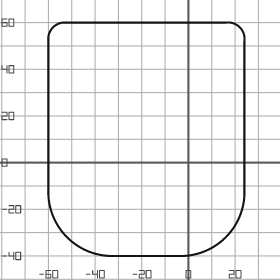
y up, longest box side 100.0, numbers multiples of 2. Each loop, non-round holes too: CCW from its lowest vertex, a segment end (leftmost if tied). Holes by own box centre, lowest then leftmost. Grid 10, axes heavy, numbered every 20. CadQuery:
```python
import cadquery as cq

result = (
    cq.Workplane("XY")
    .moveTo(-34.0, -40.0)
    .lineTo(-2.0, -40.0)
    .threePointArc((16.0, -32.0), (24.0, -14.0))
    .lineTo(24.0, 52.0)
    .threePointArc((22.0, 58.0), (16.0, 60.0))
    .lineTo(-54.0, 60.0)
    .threePointArc((-58.0, 58.0), (-60.0, 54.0))
    .lineTo(-60.0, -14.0)
    .threePointArc((-52.0, -32.0), (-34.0, -40.0))
    .close()
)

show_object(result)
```